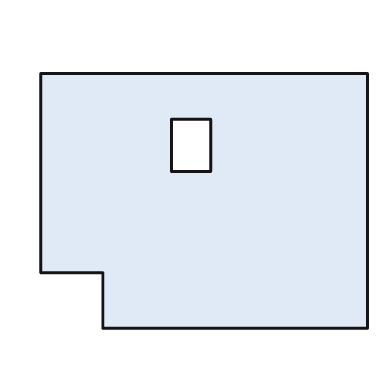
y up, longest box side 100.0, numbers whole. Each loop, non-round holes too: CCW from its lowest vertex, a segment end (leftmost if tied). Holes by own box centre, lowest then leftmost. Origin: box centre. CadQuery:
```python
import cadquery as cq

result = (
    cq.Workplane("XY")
    .moveTo(-31.0, -39.0)
    .lineTo(50.0, -39.0)
    .lineTo(50.0, 39.0)
    .lineTo(-50.0, 39.0)
    .lineTo(-50.0, -22.0)
    .lineTo(-31.0, -22.0)
    .close()
    .moveTo(-10.0, 9.0)
    .lineTo(2.0, 9.0)
    .lineTo(2.0, 25.0)
    .lineTo(-10.0, 25.0)
    .close()
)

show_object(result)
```